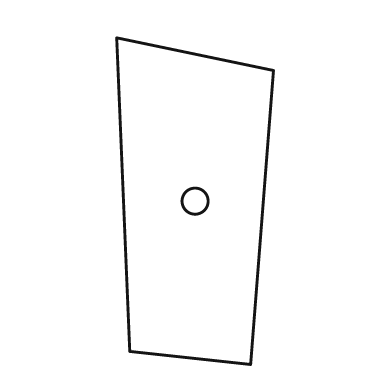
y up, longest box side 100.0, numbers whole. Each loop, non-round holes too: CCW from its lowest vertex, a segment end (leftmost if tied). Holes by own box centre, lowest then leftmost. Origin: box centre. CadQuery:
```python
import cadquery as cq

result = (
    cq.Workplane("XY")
    .moveTo(17.0, -50.0)
    .lineTo(24.0, 40.0)
    .lineTo(-24.0, 50.0)
    .lineTo(-20.0, -46.0)
    .close()
    .moveTo(0.0, 0.0)
    .circle(4.0)
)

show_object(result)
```